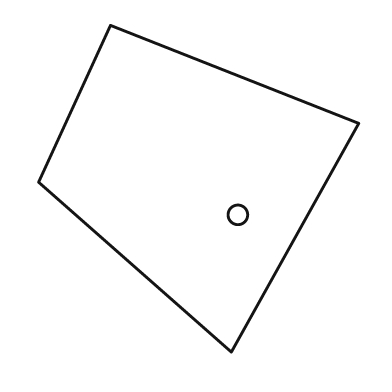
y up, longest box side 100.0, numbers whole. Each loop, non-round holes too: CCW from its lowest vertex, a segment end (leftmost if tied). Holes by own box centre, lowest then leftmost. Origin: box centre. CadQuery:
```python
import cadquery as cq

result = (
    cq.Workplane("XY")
    .moveTo(10.0, -50.0)
    .lineTo(49.0, 20.0)
    .lineTo(-27.0, 50.0)
    .lineTo(-49.0, 2.0)
    .close()
    .moveTo(12.0, -8.0)
    .circle(3.0)
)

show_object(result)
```